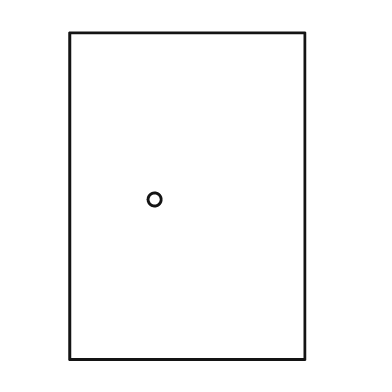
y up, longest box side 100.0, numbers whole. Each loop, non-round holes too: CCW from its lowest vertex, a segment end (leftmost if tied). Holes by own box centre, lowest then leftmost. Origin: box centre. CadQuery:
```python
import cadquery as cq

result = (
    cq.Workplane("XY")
    .moveTo(-36.0, -50.0)
    .lineTo(36.0, -50.0)
    .lineTo(36.0, 50.0)
    .lineTo(-36.0, 50.0)
    .close()
    .moveTo(-10.0, -1.0)
    .circle(2.0)
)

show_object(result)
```